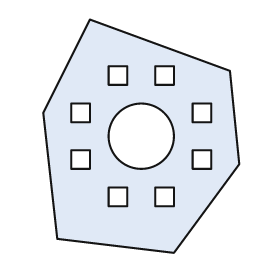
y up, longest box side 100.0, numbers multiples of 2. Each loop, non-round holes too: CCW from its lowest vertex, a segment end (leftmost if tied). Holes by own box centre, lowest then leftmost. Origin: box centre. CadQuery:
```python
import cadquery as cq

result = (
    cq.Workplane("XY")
    .moveTo(14.0, -50.0)
    .lineTo(42.0, -12.0)
    .lineTo(38.0, 28.0)
    .lineTo(-22.0, 50.0)
    .lineTo(-42.0, 10.0)
    .lineTo(-36.0, -44.0)
    .close()
    .moveTo(-14.0, -30.0)
    .lineTo(-6.0, -30.0)
    .lineTo(-6.0, -22.0)
    .lineTo(-14.0, -22.0)
    .close()
    .moveTo(6.0, -30.0)
    .lineTo(14.0, -30.0)
    .lineTo(14.0, -22.0)
    .lineTo(6.0, -22.0)
    .close()
    .moveTo(-30.0, -14.0)
    .lineTo(-22.0, -14.0)
    .lineTo(-22.0, -6.0)
    .lineTo(-30.0, -6.0)
    .close()
    .moveTo(22.0, -14.0)
    .lineTo(30.0, -14.0)
    .lineTo(30.0, -6.0)
    .lineTo(22.0, -6.0)
    .close()
    .moveTo(0.0, 0.0)
    .circle(14.0)
    .moveTo(-30.0, 6.0)
    .lineTo(-22.0, 6.0)
    .lineTo(-22.0, 14.0)
    .lineTo(-30.0, 14.0)
    .close()
    .moveTo(22.0, 6.0)
    .lineTo(30.0, 6.0)
    .lineTo(30.0, 14.0)
    .lineTo(22.0, 14.0)
    .close()
    .moveTo(-14.0, 22.0)
    .lineTo(-6.0, 22.0)
    .lineTo(-6.0, 30.0)
    .lineTo(-14.0, 30.0)
    .close()
    .moveTo(6.0, 22.0)
    .lineTo(14.0, 22.0)
    .lineTo(14.0, 30.0)
    .lineTo(6.0, 30.0)
    .close()
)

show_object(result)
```